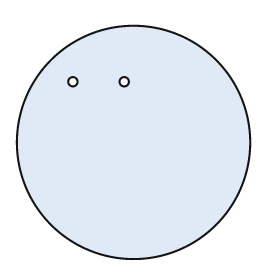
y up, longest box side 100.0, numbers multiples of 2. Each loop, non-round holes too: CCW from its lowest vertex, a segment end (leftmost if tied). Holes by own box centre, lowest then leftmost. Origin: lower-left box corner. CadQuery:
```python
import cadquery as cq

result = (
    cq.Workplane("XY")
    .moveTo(50.0, 50.0)
    .circle(50.0)
    .moveTo(24.0, 76.0)
    .circle(2.0)
    .moveTo(46.0, 76.0)
    .circle(2.0)
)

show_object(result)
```